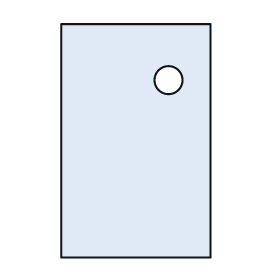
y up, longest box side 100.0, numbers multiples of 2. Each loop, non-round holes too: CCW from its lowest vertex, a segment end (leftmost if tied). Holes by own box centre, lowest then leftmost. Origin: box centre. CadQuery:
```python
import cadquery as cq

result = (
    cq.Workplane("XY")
    .moveTo(-32.0, -50.0)
    .lineTo(32.0, -50.0)
    .lineTo(32.0, 50.0)
    .lineTo(-32.0, 50.0)
    .close()
    .moveTo(14.0, 26.0)
    .circle(6.0)
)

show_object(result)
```